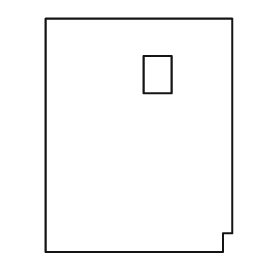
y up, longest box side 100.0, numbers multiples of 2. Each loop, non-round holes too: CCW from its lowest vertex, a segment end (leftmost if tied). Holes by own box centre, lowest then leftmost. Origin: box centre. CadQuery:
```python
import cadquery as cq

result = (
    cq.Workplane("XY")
    .moveTo(-40.0, -50.0)
    .lineTo(36.0, -50.0)
    .lineTo(36.0, -42.0)
    .lineTo(40.0, -42.0)
    .lineTo(40.0, 50.0)
    .lineTo(-40.0, 50.0)
    .close()
    .moveTo(2.0, 18.0)
    .lineTo(14.0, 18.0)
    .lineTo(14.0, 34.0)
    .lineTo(2.0, 34.0)
    .close()
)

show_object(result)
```